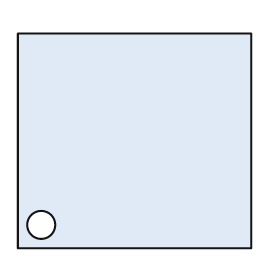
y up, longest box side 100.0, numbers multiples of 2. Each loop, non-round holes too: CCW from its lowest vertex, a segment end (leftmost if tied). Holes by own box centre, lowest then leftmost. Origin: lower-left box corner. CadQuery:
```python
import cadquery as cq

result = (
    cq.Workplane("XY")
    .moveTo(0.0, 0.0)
    .lineTo(100.0, 0.0)
    .lineTo(100.0, 92.0)
    .lineTo(0.0, 92.0)
    .close()
    .moveTo(10.0, 10.0)
    .circle(6.0)
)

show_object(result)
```